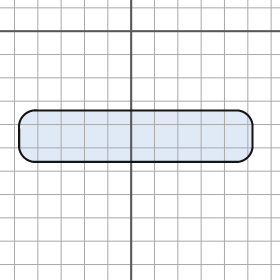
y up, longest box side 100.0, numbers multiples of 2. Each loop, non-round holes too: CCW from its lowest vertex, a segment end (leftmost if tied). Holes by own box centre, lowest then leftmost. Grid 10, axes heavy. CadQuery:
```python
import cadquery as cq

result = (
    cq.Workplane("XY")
    .moveTo(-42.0, -56.0)
    .lineTo(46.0, -56.0)
    .threePointArc((50.0, -54.0), (52.0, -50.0))
    .lineTo(52.0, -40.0)
    .threePointArc((50.0, -36.0), (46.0, -34.0))
    .lineTo(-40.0, -34.0)
    .threePointArc((-46.0, -36.0), (-48.0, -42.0))
    .lineTo(-48.0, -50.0)
    .threePointArc((-46.0, -54.0), (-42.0, -56.0))
    .close()
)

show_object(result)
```